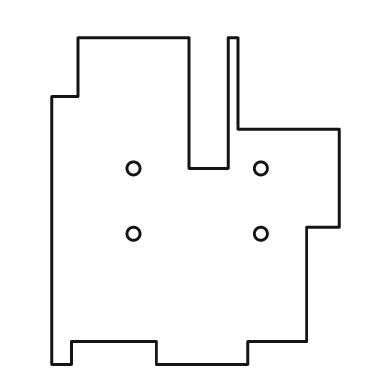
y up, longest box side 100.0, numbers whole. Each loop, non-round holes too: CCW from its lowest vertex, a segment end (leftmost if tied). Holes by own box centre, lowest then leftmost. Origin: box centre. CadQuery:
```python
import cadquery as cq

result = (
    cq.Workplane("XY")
    .moveTo(-44.0, -50.0)
    .lineTo(-38.0, -50.0)
    .lineTo(-38.0, -43.0)
    .lineTo(-12.0, -43.0)
    .lineTo(-12.0, -50.0)
    .lineTo(16.0, -50.0)
    .lineTo(16.0, -43.0)
    .lineTo(34.0, -43.0)
    .lineTo(34.0, -8.0)
    .lineTo(44.0, -8.0)
    .lineTo(44.0, 22.0)
    .lineTo(13.0, 22.0)
    .lineTo(13.0, 50.0)
    .lineTo(10.0, 50.0)
    .lineTo(10.0, 10.0)
    .lineTo(-2.0, 10.0)
    .lineTo(-2.0, 50.0)
    .lineTo(-36.0, 50.0)
    .lineTo(-36.0, 32.0)
    .lineTo(-44.0, 32.0)
    .close()
    .moveTo(-19.0, -10.0)
    .circle(2.0)
    .moveTo(20.0, -10.0)
    .circle(2.0)
    .moveTo(-19.0, 10.0)
    .circle(2.0)
    .moveTo(20.0, 10.0)
    .circle(2.0)
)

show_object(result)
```